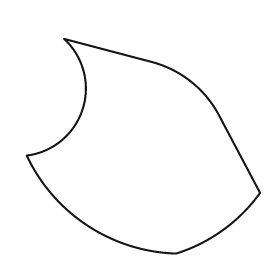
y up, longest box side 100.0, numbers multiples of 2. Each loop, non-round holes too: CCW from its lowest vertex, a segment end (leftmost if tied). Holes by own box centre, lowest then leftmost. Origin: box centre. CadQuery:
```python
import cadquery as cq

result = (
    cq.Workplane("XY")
    .moveTo(14.0, -46.0)
    .threePointArc((34.0, -36.0), (50.0, -20.0))
    .lineTo(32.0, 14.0)
    .threePointArc((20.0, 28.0), (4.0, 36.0))
    .lineTo(-34.0, 46.0)
    .threePointArc((-26.0, 16.0), (-50.0, -4.0))
    .threePointArc((-24.0, -34.0), (14.0, -46.0))
    .close()
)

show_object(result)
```